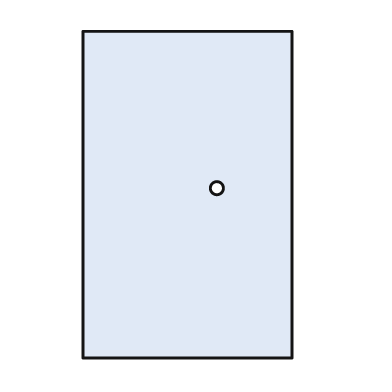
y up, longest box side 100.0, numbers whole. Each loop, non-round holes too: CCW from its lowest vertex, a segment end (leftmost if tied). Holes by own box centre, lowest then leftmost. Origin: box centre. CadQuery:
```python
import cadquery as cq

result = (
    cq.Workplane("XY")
    .moveTo(-32.0, -50.0)
    .lineTo(32.0, -50.0)
    .lineTo(32.0, 50.0)
    .lineTo(-32.0, 50.0)
    .close()
    .moveTo(9.0, 2.0)
    .circle(2.0)
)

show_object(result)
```